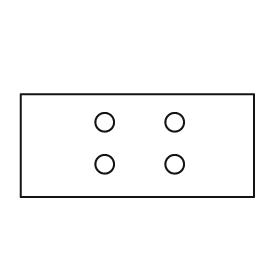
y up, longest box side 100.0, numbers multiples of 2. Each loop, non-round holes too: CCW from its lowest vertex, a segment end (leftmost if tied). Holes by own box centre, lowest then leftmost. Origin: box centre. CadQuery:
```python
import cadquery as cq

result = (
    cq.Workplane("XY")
    .moveTo(-50.0, -22.0)
    .lineTo(50.0, -22.0)
    .lineTo(50.0, 22.0)
    .lineTo(-50.0, 22.0)
    .close()
    .moveTo(-14.0, -8.0)
    .circle(4.0)
    .moveTo(16.0, -8.0)
    .circle(4.0)
    .moveTo(-14.0, 10.0)
    .circle(4.0)
    .moveTo(16.0, 10.0)
    .circle(4.0)
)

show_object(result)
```